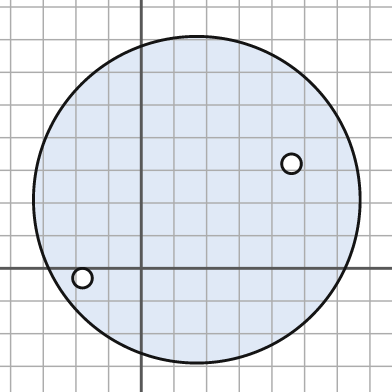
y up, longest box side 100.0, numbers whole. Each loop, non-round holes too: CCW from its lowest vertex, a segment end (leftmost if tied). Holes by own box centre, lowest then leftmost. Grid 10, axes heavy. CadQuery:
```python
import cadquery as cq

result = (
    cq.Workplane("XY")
    .moveTo(17.0, 21.0)
    .circle(50.0)
    .moveTo(-18.0, -3.0)
    .circle(3.0)
    .moveTo(46.0, 32.0)
    .circle(3.0)
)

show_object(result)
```